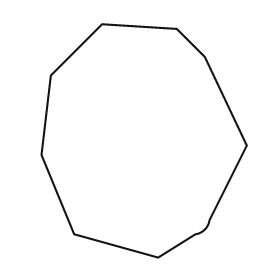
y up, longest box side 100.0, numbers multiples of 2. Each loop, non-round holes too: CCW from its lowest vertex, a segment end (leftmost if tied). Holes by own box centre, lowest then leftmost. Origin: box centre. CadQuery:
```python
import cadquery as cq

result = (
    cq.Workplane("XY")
    .moveTo(6.0, -50.0)
    .lineTo(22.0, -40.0)
    .threePointArc((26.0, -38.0), (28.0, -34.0))
    .lineTo(44.0, -2.0)
    .lineTo(26.0, 36.0)
    .lineTo(14.0, 48.0)
    .lineTo(-18.0, 50.0)
    .lineTo(-40.0, 28.0)
    .lineTo(-44.0, -6.0)
    .lineTo(-30.0, -40.0)
    .close()
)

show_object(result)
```